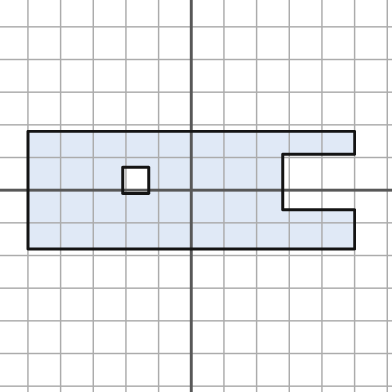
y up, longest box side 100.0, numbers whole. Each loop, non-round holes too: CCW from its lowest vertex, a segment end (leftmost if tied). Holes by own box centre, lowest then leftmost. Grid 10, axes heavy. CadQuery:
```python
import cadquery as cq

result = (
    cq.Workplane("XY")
    .moveTo(-50.0, -18.0)
    .lineTo(50.0, -18.0)
    .lineTo(50.0, -6.0)
    .lineTo(28.0, -6.0)
    .lineTo(28.0, 11.0)
    .lineTo(50.0, 11.0)
    .lineTo(50.0, 18.0)
    .lineTo(-50.0, 18.0)
    .close()
    .moveTo(-21.0, -1.0)
    .lineTo(-13.0, -1.0)
    .lineTo(-13.0, 7.0)
    .lineTo(-21.0, 7.0)
    .close()
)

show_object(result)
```